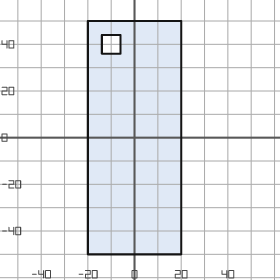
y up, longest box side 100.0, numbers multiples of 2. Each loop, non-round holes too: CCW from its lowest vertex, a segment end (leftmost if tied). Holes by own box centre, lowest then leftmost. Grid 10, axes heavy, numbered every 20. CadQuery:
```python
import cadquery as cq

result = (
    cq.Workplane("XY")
    .moveTo(-20.0, -50.0)
    .lineTo(20.0, -50.0)
    .lineTo(20.0, 50.0)
    .lineTo(-20.0, 50.0)
    .close()
    .moveTo(-14.0, 36.0)
    .lineTo(-6.0, 36.0)
    .lineTo(-6.0, 44.0)
    .lineTo(-14.0, 44.0)
    .close()
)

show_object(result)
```